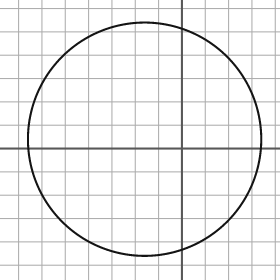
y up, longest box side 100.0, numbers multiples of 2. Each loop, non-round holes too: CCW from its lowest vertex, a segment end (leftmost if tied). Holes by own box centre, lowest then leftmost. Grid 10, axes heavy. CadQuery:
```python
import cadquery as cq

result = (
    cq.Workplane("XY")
    .moveTo(-16.0, 4.0)
    .circle(50.0)
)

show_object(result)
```